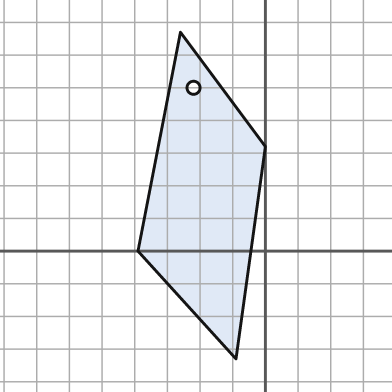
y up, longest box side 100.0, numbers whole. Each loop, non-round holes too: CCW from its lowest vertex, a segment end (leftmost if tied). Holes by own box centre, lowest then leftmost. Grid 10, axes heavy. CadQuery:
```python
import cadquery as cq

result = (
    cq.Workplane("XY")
    .moveTo(-9.0, -33.0)
    .lineTo(0.0, 32.0)
    .lineTo(-26.0, 67.0)
    .lineTo(-39.0, 0.0)
    .close()
    .moveTo(-22.0, 50.0)
    .circle(2.0)
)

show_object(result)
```